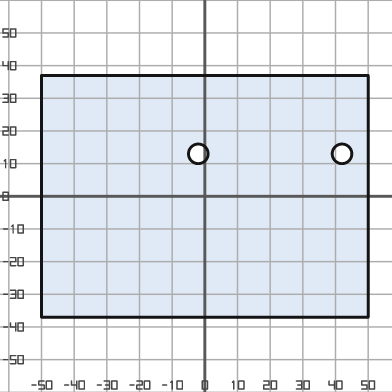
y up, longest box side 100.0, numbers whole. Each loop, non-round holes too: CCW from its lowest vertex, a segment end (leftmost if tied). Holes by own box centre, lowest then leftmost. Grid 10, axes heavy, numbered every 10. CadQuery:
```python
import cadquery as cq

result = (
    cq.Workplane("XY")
    .moveTo(-50.0, -37.0)
    .lineTo(50.0, -37.0)
    .lineTo(50.0, 37.0)
    .lineTo(-50.0, 37.0)
    .close()
    .moveTo(-2.0, 13.0)
    .circle(3.0)
    .moveTo(42.0, 13.0)
    .circle(3.0)
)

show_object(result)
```